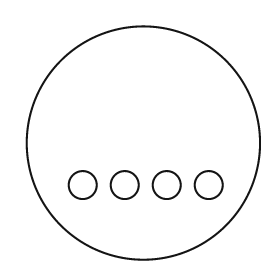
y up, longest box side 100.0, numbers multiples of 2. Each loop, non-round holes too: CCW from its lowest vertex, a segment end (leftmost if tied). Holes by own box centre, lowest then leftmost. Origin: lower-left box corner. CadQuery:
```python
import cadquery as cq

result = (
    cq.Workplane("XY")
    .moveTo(50.0, 50.0)
    .circle(50.0)
    .moveTo(24.0, 32.0)
    .circle(6.0)
    .moveTo(42.0, 32.0)
    .circle(6.0)
    .moveTo(60.0, 32.0)
    .circle(6.0)
    .moveTo(78.0, 32.0)
    .circle(6.0)
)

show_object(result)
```